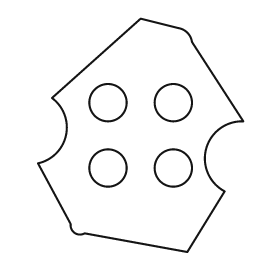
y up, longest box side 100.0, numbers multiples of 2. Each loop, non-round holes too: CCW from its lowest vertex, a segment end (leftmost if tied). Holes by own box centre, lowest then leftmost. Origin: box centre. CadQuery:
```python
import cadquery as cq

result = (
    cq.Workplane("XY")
    .moveTo(20.0, -50.0)
    .lineTo(36.0, -24.0)
    .threePointArc((28.0, -6.0), (44.0, 6.0))
    .lineTo(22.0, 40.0)
    .threePointArc((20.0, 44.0), (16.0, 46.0))
    .lineTo(0.0, 50.0)
    .lineTo(-38.0, 16.0)
    .threePointArc((-32.0, 0.0), (-44.0, -12.0))
    .lineTo(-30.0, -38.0)
    .threePointArc((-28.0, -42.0), (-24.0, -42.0))
    .close()
    .moveTo(-14.0, -14.0)
    .circle(8.0)
    .moveTo(14.0, -14.0)
    .circle(8.0)
    .moveTo(-14.0, 14.0)
    .circle(8.0)
    .moveTo(14.0, 14.0)
    .circle(8.0)
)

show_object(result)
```